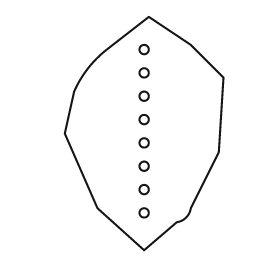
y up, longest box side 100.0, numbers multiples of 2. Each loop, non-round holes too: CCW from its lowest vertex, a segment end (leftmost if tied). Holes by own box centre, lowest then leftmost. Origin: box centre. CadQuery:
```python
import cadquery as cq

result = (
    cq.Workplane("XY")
    .moveTo(0.0, -50.0)
    .lineTo(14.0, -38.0)
    .threePointArc((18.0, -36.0), (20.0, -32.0))
    .lineTo(32.0, -8.0)
    .lineTo(34.0, 24.0)
    .lineTo(20.0, 38.0)
    .lineTo(2.0, 50.0)
    .lineTo(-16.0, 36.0)
    .threePointArc((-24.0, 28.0), (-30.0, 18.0))
    .lineTo(-34.0, 0.0)
    .lineTo(-20.0, -32.0)
    .close()
    .moveTo(0.0, -34.0)
    .circle(2.0)
    .moveTo(0.0, -24.0)
    .circle(2.0)
    .moveTo(0.0, -14.0)
    .circle(2.0)
    .moveTo(0.0, -4.0)
    .circle(2.0)
    .moveTo(0.0, 6.0)
    .circle(2.0)
    .moveTo(0.0, 16.0)
    .circle(2.0)
    .moveTo(0.0, 26.0)
    .circle(2.0)
    .moveTo(0.0, 36.0)
    .circle(2.0)
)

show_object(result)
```